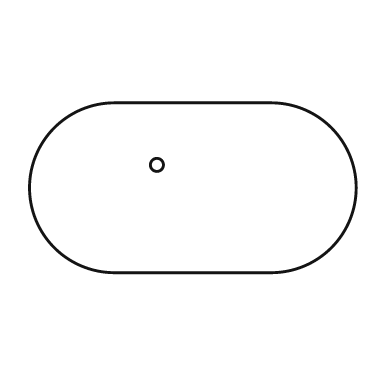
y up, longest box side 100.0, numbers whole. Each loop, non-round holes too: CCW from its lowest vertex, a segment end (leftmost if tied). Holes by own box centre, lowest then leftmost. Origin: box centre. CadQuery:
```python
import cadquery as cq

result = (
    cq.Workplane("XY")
    .moveTo(-24.0, -26.0)
    .lineTo(24.0, -26.0)
    .threePointArc((50.0, 0.0), (24.0, 26.0))
    .lineTo(-24.0, 26.0)
    .threePointArc((-50.0, 0.0), (-24.0, -26.0))
    .close()
    .moveTo(-11.0, 7.0)
    .circle(2.0)
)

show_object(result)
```